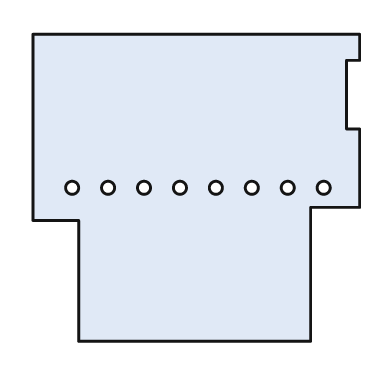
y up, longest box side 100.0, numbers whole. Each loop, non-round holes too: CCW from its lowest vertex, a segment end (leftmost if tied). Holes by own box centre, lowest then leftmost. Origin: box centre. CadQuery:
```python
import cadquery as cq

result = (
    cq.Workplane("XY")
    .moveTo(-36.0, -47.0)
    .lineTo(35.0, -47.0)
    .lineTo(35.0, -6.0)
    .lineTo(50.0, -6.0)
    .lineTo(50.0, 18.0)
    .lineTo(46.0, 18.0)
    .lineTo(46.0, 39.0)
    .lineTo(50.0, 39.0)
    .lineTo(50.0, 47.0)
    .lineTo(-50.0, 47.0)
    .lineTo(-50.0, -10.0)
    .lineTo(-36.0, -10.0)
    .close()
    .moveTo(-38.0, 0.0)
    .circle(2.0)
    .moveTo(-27.0, 0.0)
    .circle(2.0)
    .moveTo(-16.0, 0.0)
    .circle(2.0)
    .moveTo(-5.0, 0.0)
    .circle(2.0)
    .moveTo(6.0, 0.0)
    .circle(2.0)
    .moveTo(17.0, 0.0)
    .circle(2.0)
    .moveTo(28.0, 0.0)
    .circle(2.0)
    .moveTo(39.0, 0.0)
    .circle(2.0)
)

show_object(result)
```